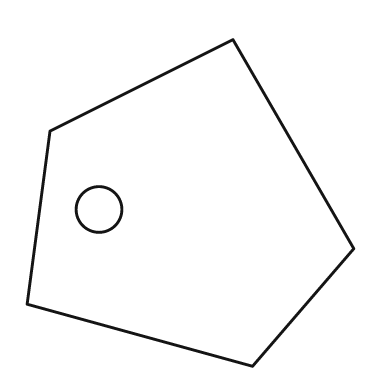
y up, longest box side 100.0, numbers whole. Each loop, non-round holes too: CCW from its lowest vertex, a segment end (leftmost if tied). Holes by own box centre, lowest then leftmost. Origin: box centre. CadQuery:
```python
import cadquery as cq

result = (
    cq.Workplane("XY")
    .moveTo(19.0, -50.0)
    .lineTo(50.0, -14.0)
    .lineTo(13.0, 50.0)
    .lineTo(-43.0, 22.0)
    .lineTo(-50.0, -31.0)
    .close()
    .moveTo(-28.0, -2.0)
    .circle(7.0)
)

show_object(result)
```